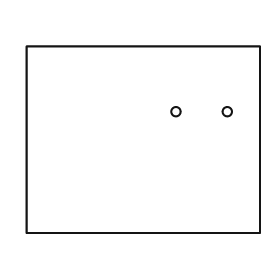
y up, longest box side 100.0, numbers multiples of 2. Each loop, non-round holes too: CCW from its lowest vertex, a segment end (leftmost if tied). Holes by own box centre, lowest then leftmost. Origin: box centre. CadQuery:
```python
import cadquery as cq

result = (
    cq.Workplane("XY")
    .moveTo(-50.0, -40.0)
    .lineTo(50.0, -40.0)
    .lineTo(50.0, 40.0)
    .lineTo(-50.0, 40.0)
    .close()
    .moveTo(14.0, 12.0)
    .circle(2.0)
    .moveTo(36.0, 12.0)
    .circle(2.0)
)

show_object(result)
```